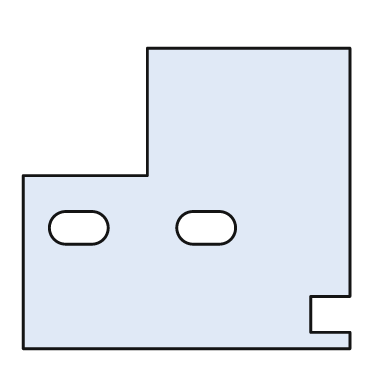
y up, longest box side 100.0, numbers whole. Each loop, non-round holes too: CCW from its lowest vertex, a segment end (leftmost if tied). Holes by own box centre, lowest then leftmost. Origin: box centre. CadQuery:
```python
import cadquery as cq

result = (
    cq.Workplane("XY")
    .moveTo(-50.0, -46.0)
    .lineTo(50.0, -46.0)
    .lineTo(50.0, -41.0)
    .lineTo(38.0, -41.0)
    .lineTo(38.0, -30.0)
    .lineTo(50.0, -30.0)
    .lineTo(50.0, 46.0)
    .lineTo(-12.0, 46.0)
    .lineTo(-12.0, 7.0)
    .lineTo(-50.0, 7.0)
    .close()
    .moveTo(-37.0, -14.0)
    .lineTo(-29.0, -14.0)
    .threePointArc((-24.0, -9.0), (-29.0, -4.0))
    .lineTo(-37.0, -4.0)
    .threePointArc((-42.0, -9.0), (-37.0, -14.0))
    .close()
    .moveTo(2.0, -14.0)
    .lineTo(10.0, -14.0)
    .threePointArc((15.0, -9.0), (10.0, -4.0))
    .lineTo(2.0, -4.0)
    .threePointArc((-3.0, -9.0), (2.0, -14.0))
    .close()
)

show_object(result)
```